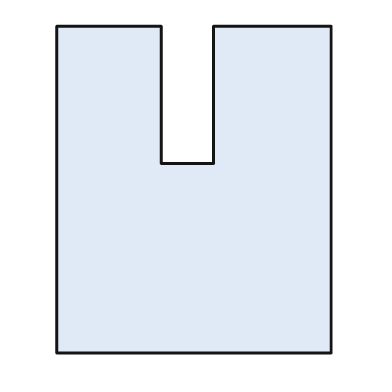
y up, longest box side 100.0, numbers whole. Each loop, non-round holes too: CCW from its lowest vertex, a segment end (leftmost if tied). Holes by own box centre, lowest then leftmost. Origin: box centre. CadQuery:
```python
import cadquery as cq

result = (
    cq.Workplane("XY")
    .moveTo(-42.0, -50.0)
    .lineTo(42.0, -50.0)
    .lineTo(42.0, 50.0)
    .lineTo(6.0, 50.0)
    .lineTo(6.0, 8.0)
    .lineTo(-10.0, 8.0)
    .lineTo(-10.0, 50.0)
    .lineTo(-42.0, 50.0)
    .close()
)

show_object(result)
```